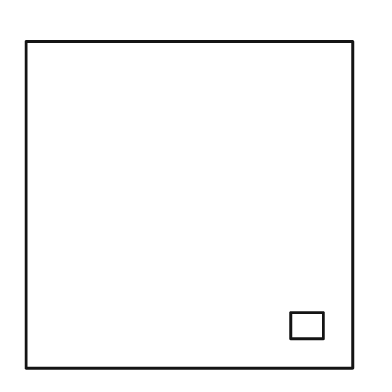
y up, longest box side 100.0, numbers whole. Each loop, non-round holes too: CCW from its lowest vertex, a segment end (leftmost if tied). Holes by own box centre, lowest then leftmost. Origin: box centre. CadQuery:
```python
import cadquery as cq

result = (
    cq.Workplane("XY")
    .moveTo(-50.0, -50.0)
    .lineTo(50.0, -50.0)
    .lineTo(50.0, 50.0)
    .lineTo(-50.0, 50.0)
    .close()
    .moveTo(31.0, -41.0)
    .lineTo(41.0, -41.0)
    .lineTo(41.0, -33.0)
    .lineTo(31.0, -33.0)
    .close()
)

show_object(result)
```